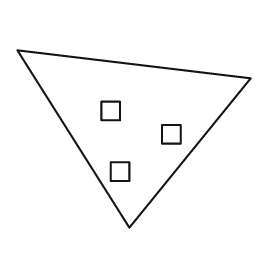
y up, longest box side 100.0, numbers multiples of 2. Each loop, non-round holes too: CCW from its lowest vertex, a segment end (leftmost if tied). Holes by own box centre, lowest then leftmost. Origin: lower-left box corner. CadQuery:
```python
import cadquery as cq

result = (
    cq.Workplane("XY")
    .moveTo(48.0, 0.0)
    .lineTo(100.0, 64.0)
    .lineTo(0.0, 76.0)
    .close()
    .moveTo(40.0, 20.0)
    .lineTo(48.0, 20.0)
    .lineTo(48.0, 28.0)
    .lineTo(40.0, 28.0)
    .close()
    .moveTo(62.0, 36.0)
    .lineTo(70.0, 36.0)
    .lineTo(70.0, 44.0)
    .lineTo(62.0, 44.0)
    .close()
    .moveTo(36.0, 46.0)
    .lineTo(44.0, 46.0)
    .lineTo(44.0, 54.0)
    .lineTo(36.0, 54.0)
    .close()
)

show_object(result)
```